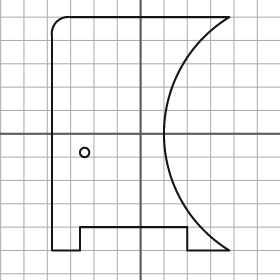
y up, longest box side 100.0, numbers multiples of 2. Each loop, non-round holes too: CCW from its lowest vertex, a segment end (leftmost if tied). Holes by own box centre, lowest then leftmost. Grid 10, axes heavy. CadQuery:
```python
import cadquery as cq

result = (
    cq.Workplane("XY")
    .moveTo(-38.0, -50.0)
    .lineTo(-26.0, -50.0)
    .lineTo(-26.0, -40.0)
    .lineTo(20.0, -40.0)
    .lineTo(20.0, -50.0)
    .lineTo(38.0, -50.0)
    .threePointArc((10.0, 0.0), (38.0, 50.0))
    .lineTo(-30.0, 50.0)
    .threePointArc((-36.0, 48.0), (-38.0, 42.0))
    .close()
    .moveTo(-24.0, -8.0)
    .circle(2.0)
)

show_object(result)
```